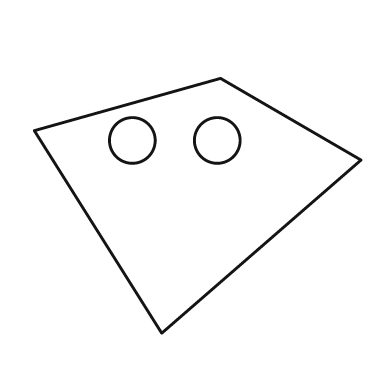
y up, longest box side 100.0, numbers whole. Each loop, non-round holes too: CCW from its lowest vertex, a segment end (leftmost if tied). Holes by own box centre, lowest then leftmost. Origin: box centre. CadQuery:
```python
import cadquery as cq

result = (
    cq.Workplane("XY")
    .moveTo(-11.0, -39.0)
    .lineTo(50.0, 14.0)
    .lineTo(7.0, 39.0)
    .lineTo(-50.0, 23.0)
    .close()
    .moveTo(-20.0, 20.0)
    .circle(7.0)
    .moveTo(6.0, 20.0)
    .circle(7.0)
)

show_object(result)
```